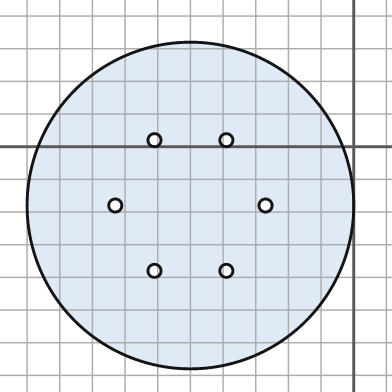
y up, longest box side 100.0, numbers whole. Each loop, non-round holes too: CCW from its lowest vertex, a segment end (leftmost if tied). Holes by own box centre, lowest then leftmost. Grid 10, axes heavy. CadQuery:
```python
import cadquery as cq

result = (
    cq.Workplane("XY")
    .moveTo(-50.0, -18.0)
    .circle(50.0)
    .moveTo(-61.0, -38.0)
    .circle(2.0)
    .moveTo(-39.0, -38.0)
    .circle(2.0)
    .moveTo(-73.0, -18.0)
    .circle(2.0)
    .moveTo(-27.0, -18.0)
    .circle(2.0)
    .moveTo(-61.0, 2.0)
    .circle(2.0)
    .moveTo(-39.0, 2.0)
    .circle(2.0)
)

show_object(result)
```